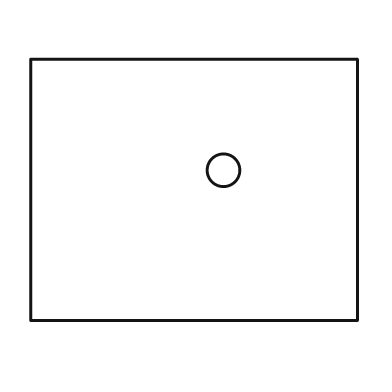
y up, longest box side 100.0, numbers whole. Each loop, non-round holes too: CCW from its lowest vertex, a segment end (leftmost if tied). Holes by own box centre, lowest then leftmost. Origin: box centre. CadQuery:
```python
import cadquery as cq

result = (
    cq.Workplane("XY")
    .moveTo(-50.0, -40.0)
    .lineTo(50.0, -40.0)
    .lineTo(50.0, 40.0)
    .lineTo(-50.0, 40.0)
    .close()
    .moveTo(9.0, 6.0)
    .circle(5.0)
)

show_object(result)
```